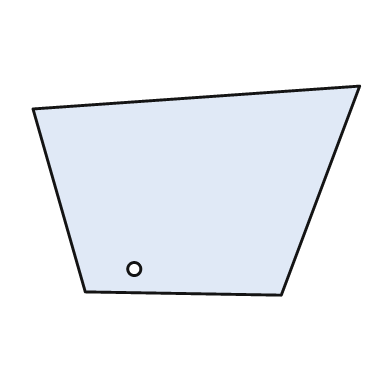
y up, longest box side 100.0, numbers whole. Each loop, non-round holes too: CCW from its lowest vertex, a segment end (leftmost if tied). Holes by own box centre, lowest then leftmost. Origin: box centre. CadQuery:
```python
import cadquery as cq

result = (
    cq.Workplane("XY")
    .moveTo(26.0, -32.0)
    .lineTo(50.0, 32.0)
    .lineTo(-50.0, 25.0)
    .lineTo(-34.0, -31.0)
    .close()
    .moveTo(-19.0, -24.0)
    .circle(2.0)
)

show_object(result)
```